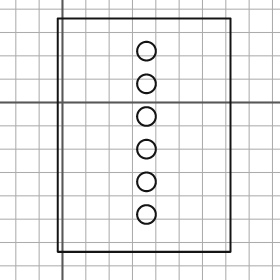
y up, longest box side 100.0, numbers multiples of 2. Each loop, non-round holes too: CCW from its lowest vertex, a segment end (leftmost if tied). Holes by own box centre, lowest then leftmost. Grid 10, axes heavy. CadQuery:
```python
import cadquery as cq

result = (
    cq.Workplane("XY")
    .moveTo(-2.0, -64.0)
    .lineTo(72.0, -64.0)
    .lineTo(72.0, 36.0)
    .lineTo(-2.0, 36.0)
    .close()
    .moveTo(36.0, -48.0)
    .circle(4.0)
    .moveTo(36.0, -34.0)
    .circle(4.0)
    .moveTo(36.0, -20.0)
    .circle(4.0)
    .moveTo(36.0, -6.0)
    .circle(4.0)
    .moveTo(36.0, 8.0)
    .circle(4.0)
    .moveTo(36.0, 22.0)
    .circle(4.0)
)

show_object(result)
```